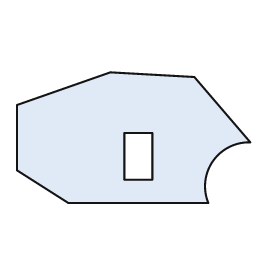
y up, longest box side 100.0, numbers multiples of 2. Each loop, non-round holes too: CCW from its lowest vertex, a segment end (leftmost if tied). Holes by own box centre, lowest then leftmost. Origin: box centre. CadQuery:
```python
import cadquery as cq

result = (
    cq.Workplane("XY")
    .moveTo(-28.0, -28.0)
    .lineTo(32.0, -28.0)
    .threePointArc((34.0, -10.0), (50.0, -2.0))
    .lineTo(26.0, 26.0)
    .lineTo(-10.0, 28.0)
    .lineTo(-50.0, 14.0)
    .lineTo(-50.0, -14.0)
    .close()
    .moveTo(-4.0, -18.0)
    .lineTo(8.0, -18.0)
    .lineTo(8.0, 2.0)
    .lineTo(-4.0, 2.0)
    .close()
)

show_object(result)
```